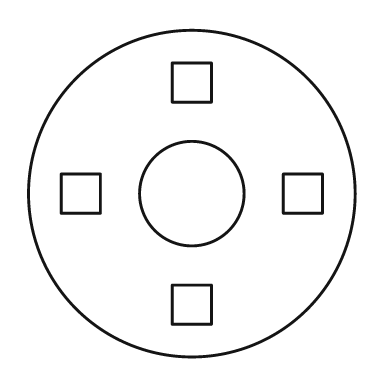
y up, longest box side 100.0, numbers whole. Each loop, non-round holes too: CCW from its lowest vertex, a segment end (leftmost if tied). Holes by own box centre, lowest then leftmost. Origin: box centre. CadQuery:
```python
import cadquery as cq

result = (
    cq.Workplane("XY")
    .moveTo(0.0, 0.0)
    .circle(50.0)
    .moveTo(-6.0, -40.0)
    .lineTo(6.0, -40.0)
    .lineTo(6.0, -28.0)
    .lineTo(-6.0, -28.0)
    .close()
    .moveTo(-40.0, -6.0)
    .lineTo(-28.0, -6.0)
    .lineTo(-28.0, 6.0)
    .lineTo(-40.0, 6.0)
    .close()
    .moveTo(0.0, 0.0)
    .circle(16.0)
    .moveTo(28.0, -6.0)
    .lineTo(40.0, -6.0)
    .lineTo(40.0, 6.0)
    .lineTo(28.0, 6.0)
    .close()
    .moveTo(-6.0, 28.0)
    .lineTo(6.0, 28.0)
    .lineTo(6.0, 40.0)
    .lineTo(-6.0, 40.0)
    .close()
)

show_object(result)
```